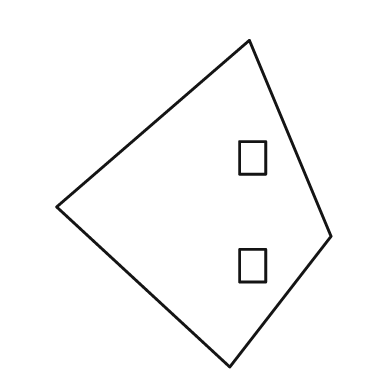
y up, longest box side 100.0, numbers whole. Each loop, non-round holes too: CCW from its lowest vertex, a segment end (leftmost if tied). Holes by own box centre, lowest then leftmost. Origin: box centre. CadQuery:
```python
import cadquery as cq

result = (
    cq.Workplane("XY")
    .moveTo(11.0, -50.0)
    .lineTo(42.0, -10.0)
    .lineTo(17.0, 50.0)
    .lineTo(-42.0, -1.0)
    .close()
    .moveTo(14.0, -24.0)
    .lineTo(22.0, -24.0)
    .lineTo(22.0, -14.0)
    .lineTo(14.0, -14.0)
    .close()
    .moveTo(14.0, 9.0)
    .lineTo(22.0, 9.0)
    .lineTo(22.0, 19.0)
    .lineTo(14.0, 19.0)
    .close()
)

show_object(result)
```